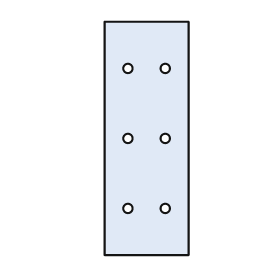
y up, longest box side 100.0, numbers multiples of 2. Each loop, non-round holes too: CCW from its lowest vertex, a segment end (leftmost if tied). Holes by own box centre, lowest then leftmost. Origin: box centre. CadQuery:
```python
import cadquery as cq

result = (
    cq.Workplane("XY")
    .moveTo(-18.0, -50.0)
    .lineTo(18.0, -50.0)
    .lineTo(18.0, 50.0)
    .lineTo(-18.0, 50.0)
    .close()
    .moveTo(-8.0, -30.0)
    .circle(2.0)
    .moveTo(8.0, -30.0)
    .circle(2.0)
    .moveTo(-8.0, 0.0)
    .circle(2.0)
    .moveTo(8.0, 0.0)
    .circle(2.0)
    .moveTo(-8.0, 30.0)
    .circle(2.0)
    .moveTo(8.0, 30.0)
    .circle(2.0)
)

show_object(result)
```